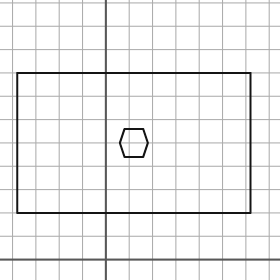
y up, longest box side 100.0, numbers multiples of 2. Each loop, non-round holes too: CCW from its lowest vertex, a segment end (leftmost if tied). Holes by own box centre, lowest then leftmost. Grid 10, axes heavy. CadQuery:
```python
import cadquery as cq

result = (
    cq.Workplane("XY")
    .moveTo(-38.0, 20.0)
    .lineTo(62.0, 20.0)
    .lineTo(62.0, 80.0)
    .lineTo(-38.0, 80.0)
    .close()
    .moveTo(8.0, 44.0)
    .lineTo(16.0, 44.0)
    .lineTo(18.0, 50.0)
    .lineTo(16.0, 56.0)
    .lineTo(8.0, 56.0)
    .lineTo(6.0, 50.0)
    .close()
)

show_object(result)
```